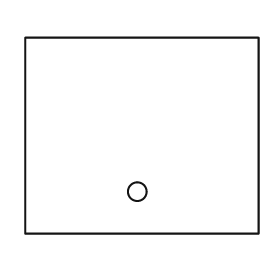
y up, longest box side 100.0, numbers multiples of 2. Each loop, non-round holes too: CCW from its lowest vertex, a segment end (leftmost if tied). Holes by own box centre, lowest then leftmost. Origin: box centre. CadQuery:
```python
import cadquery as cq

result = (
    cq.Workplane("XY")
    .moveTo(-50.0, -42.0)
    .lineTo(50.0, -42.0)
    .lineTo(50.0, 42.0)
    .lineTo(-50.0, 42.0)
    .close()
    .moveTo(-2.0, -24.0)
    .circle(4.0)
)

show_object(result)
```